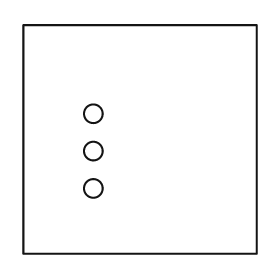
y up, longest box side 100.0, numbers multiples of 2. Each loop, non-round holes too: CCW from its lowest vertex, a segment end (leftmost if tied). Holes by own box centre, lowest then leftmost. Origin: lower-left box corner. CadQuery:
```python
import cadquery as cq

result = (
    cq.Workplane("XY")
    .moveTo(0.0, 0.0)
    .lineTo(100.0, 0.0)
    .lineTo(100.0, 98.0)
    .lineTo(0.0, 98.0)
    .close()
    .moveTo(30.0, 28.0)
    .circle(4.0)
    .moveTo(30.0, 44.0)
    .circle(4.0)
    .moveTo(30.0, 60.0)
    .circle(4.0)
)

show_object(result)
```